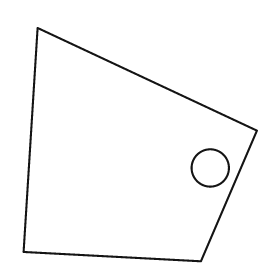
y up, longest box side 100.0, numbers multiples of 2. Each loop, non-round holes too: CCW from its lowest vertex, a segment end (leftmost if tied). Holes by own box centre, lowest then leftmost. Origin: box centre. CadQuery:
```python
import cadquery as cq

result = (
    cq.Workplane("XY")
    .moveTo(26.0, -50.0)
    .lineTo(50.0, 6.0)
    .lineTo(-44.0, 50.0)
    .lineTo(-50.0, -46.0)
    .close()
    .moveTo(30.0, -10.0)
    .circle(8.0)
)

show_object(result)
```